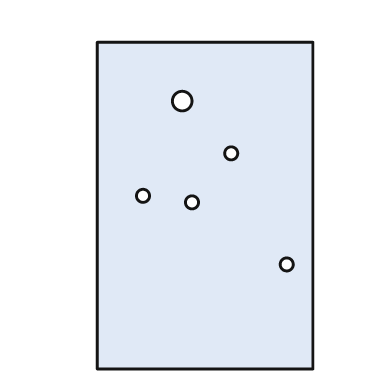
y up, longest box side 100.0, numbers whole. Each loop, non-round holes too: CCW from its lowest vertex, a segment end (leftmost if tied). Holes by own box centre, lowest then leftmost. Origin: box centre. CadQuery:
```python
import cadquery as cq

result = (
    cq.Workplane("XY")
    .moveTo(-33.0, -50.0)
    .lineTo(33.0, -50.0)
    .lineTo(33.0, 50.0)
    .lineTo(-33.0, 50.0)
    .close()
    .moveTo(25.0, -18.0)
    .circle(2.0)
    .moveTo(-4.0, 1.0)
    .circle(2.0)
    .moveTo(-19.0, 3.0)
    .circle(2.0)
    .moveTo(8.0, 16.0)
    .circle(2.0)
    .moveTo(-7.0, 32.0)
    .circle(3.0)
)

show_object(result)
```